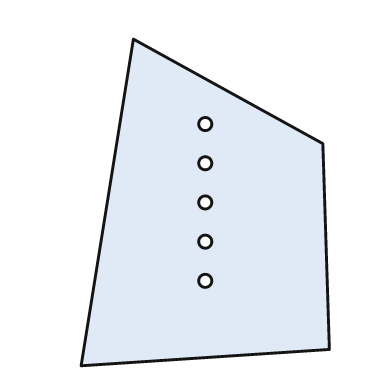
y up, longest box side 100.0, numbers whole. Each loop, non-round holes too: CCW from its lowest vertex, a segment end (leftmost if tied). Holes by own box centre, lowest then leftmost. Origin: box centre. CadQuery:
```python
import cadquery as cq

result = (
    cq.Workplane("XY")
    .moveTo(-38.0, -50.0)
    .lineTo(38.0, -45.0)
    .lineTo(36.0, 18.0)
    .lineTo(-22.0, 50.0)
    .close()
    .moveTo(0.0, -24.0)
    .circle(2.0)
    .moveTo(0.0, -12.0)
    .circle(2.0)
    .moveTo(0.0, 0.0)
    .circle(2.0)
    .moveTo(0.0, 12.0)
    .circle(2.0)
    .moveTo(0.0, 24.0)
    .circle(2.0)
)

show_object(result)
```